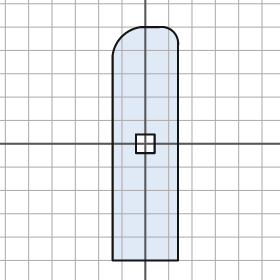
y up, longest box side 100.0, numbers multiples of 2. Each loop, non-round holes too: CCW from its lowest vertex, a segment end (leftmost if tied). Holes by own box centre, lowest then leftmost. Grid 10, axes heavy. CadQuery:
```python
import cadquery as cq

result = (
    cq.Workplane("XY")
    .moveTo(-14.0, -50.0)
    .lineTo(14.0, -50.0)
    .lineTo(14.0, 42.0)
    .threePointArc((12.0, 48.0), (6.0, 50.0))
    .lineTo(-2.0, 50.0)
    .threePointArc((-10.0, 46.0), (-14.0, 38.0))
    .close()
    .moveTo(-4.0, -4.0)
    .lineTo(4.0, -4.0)
    .lineTo(4.0, 4.0)
    .lineTo(-4.0, 4.0)
    .close()
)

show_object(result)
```